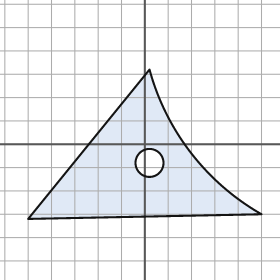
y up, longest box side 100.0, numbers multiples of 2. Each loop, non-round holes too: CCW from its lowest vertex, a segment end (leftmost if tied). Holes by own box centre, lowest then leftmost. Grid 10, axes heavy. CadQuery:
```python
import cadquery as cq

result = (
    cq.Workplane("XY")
    .moveTo(-50.0, -32.0)
    .lineTo(50.0, -30.0)
    .threePointArc((20.0, -4.0), (2.0, 32.0))
    .close()
    .moveTo(2.0, -8.0)
    .circle(6.0)
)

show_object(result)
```